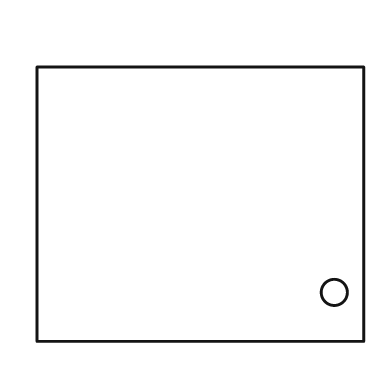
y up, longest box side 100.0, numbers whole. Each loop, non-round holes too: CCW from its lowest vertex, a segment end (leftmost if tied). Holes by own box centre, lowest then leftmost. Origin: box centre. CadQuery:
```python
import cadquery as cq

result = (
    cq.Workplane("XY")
    .moveTo(-50.0, -42.0)
    .lineTo(50.0, -42.0)
    .lineTo(50.0, 42.0)
    .lineTo(-50.0, 42.0)
    .close()
    .moveTo(41.0, -27.0)
    .circle(4.0)
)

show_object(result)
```